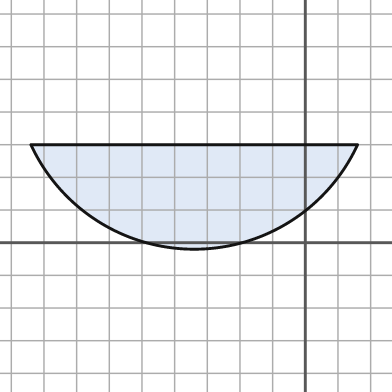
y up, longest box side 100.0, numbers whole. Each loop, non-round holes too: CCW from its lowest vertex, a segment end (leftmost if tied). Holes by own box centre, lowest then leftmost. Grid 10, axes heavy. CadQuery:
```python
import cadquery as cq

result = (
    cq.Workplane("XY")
    .moveTo(-84.0, 30.0)
    .threePointArc((-34.0, -2.0), (16.0, 30.0))
    .close()
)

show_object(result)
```